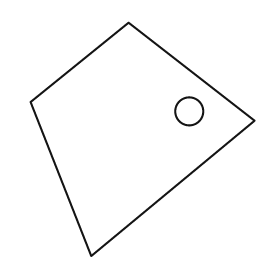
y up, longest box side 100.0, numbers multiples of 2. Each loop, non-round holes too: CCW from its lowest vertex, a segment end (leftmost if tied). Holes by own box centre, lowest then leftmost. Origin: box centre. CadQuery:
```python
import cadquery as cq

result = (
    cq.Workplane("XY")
    .moveTo(-22.0, -50.0)
    .lineTo(48.0, 8.0)
    .lineTo(-6.0, 50.0)
    .lineTo(-48.0, 16.0)
    .close()
    .moveTo(20.0, 12.0)
    .circle(6.0)
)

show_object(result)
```